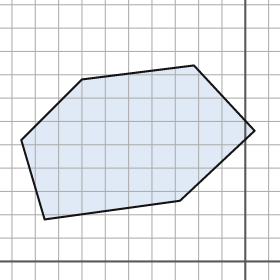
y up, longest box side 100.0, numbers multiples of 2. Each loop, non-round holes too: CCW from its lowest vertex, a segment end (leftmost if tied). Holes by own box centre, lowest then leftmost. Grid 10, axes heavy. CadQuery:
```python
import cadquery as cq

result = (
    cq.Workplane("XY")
    .moveTo(-86.0, 18.0)
    .lineTo(-28.0, 26.0)
    .lineTo(4.0, 56.0)
    .lineTo(-22.0, 84.0)
    .lineTo(-70.0, 78.0)
    .lineTo(-96.0, 52.0)
    .close()
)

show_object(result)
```